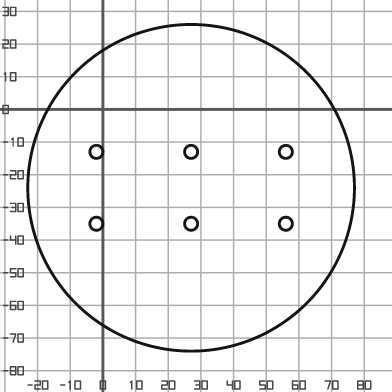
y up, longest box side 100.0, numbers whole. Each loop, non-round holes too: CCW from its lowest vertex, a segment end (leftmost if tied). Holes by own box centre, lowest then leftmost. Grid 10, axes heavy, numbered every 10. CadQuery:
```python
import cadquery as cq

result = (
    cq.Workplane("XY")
    .moveTo(27.0, -24.0)
    .circle(50.0)
    .moveTo(-2.0, -35.0)
    .circle(2.0)
    .moveTo(27.0, -35.0)
    .circle(2.0)
    .moveTo(56.0, -35.0)
    .circle(2.0)
    .moveTo(-2.0, -13.0)
    .circle(2.0)
    .moveTo(27.0, -13.0)
    .circle(2.0)
    .moveTo(56.0, -13.0)
    .circle(2.0)
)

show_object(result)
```